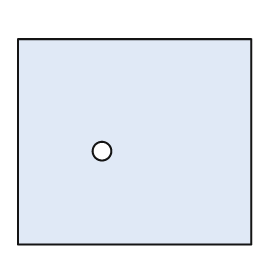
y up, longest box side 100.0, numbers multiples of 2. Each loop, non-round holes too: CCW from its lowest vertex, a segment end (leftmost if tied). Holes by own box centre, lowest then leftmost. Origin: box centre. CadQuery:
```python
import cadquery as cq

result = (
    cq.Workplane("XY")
    .moveTo(-50.0, -44.0)
    .lineTo(50.0, -44.0)
    .lineTo(50.0, 44.0)
    .lineTo(-50.0, 44.0)
    .close()
    .moveTo(-14.0, -4.0)
    .circle(4.0)
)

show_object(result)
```